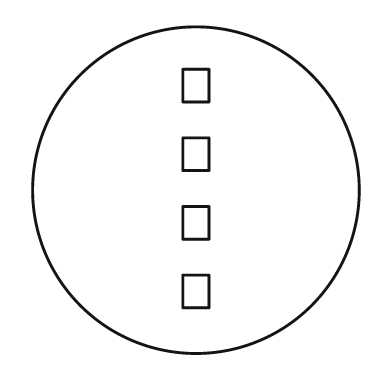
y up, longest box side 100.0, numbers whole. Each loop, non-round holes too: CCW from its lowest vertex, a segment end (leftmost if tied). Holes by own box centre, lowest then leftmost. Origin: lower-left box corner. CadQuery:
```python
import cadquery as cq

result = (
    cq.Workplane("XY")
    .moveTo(50.0, 50.0)
    .circle(50.0)
    .moveTo(46.0, 14.0)
    .lineTo(54.0, 14.0)
    .lineTo(54.0, 24.0)
    .lineTo(46.0, 24.0)
    .close()
    .moveTo(46.0, 35.0)
    .lineTo(54.0, 35.0)
    .lineTo(54.0, 45.0)
    .lineTo(46.0, 45.0)
    .close()
    .moveTo(46.0, 56.0)
    .lineTo(54.0, 56.0)
    .lineTo(54.0, 66.0)
    .lineTo(46.0, 66.0)
    .close()
    .moveTo(46.0, 77.0)
    .lineTo(54.0, 77.0)
    .lineTo(54.0, 87.0)
    .lineTo(46.0, 87.0)
    .close()
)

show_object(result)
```